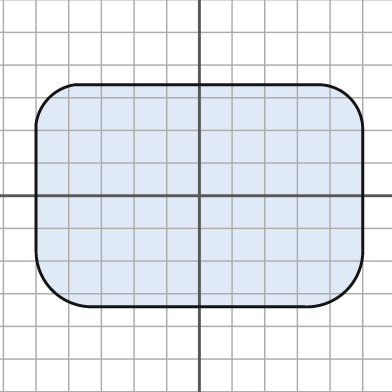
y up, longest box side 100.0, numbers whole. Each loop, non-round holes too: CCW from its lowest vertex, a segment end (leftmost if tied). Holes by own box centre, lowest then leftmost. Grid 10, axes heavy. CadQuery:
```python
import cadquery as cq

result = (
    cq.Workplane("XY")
    .moveTo(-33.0, -34.0)
    .lineTo(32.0, -34.0)
    .threePointArc((45.0, -29.0), (50.0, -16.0))
    .lineTo(50.0, 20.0)
    .threePointArc((46.0, 30.0), (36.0, 34.0))
    .lineTo(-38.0, 34.0)
    .threePointArc((-46.0, 30.0), (-50.0, 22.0))
    .lineTo(-50.0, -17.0)
    .threePointArc((-45.0, -29.0), (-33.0, -34.0))
    .close()
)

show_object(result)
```